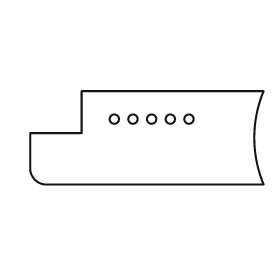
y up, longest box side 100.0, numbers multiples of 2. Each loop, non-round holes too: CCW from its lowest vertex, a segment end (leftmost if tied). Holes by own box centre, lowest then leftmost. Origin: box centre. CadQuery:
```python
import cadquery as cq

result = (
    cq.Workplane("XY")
    .moveTo(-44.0, -20.0)
    .lineTo(50.0, -20.0)
    .threePointArc((46.0, 0.0), (50.0, 20.0))
    .lineTo(-28.0, 20.0)
    .lineTo(-28.0, 2.0)
    .lineTo(-50.0, 2.0)
    .lineTo(-50.0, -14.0)
    .threePointArc((-48.0, -18.0), (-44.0, -20.0))
    .close()
    .moveTo(-14.0, 8.0)
    .circle(2.0)
    .moveTo(-6.0, 8.0)
    .circle(2.0)
    .moveTo(2.0, 8.0)
    .circle(2.0)
    .moveTo(10.0, 8.0)
    .circle(2.0)
    .moveTo(18.0, 8.0)
    .circle(2.0)
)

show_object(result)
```